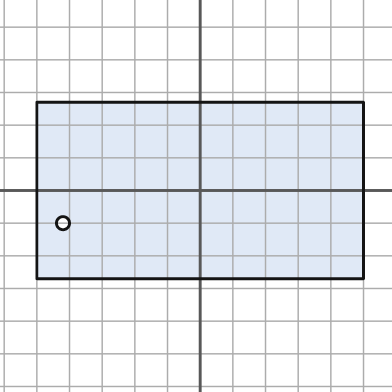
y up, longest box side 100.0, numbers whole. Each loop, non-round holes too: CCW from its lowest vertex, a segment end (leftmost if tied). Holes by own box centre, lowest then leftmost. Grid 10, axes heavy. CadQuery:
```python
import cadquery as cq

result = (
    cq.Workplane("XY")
    .moveTo(-50.0, -27.0)
    .lineTo(50.0, -27.0)
    .lineTo(50.0, 27.0)
    .lineTo(-50.0, 27.0)
    .close()
    .moveTo(-42.0, -10.0)
    .circle(2.0)
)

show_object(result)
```